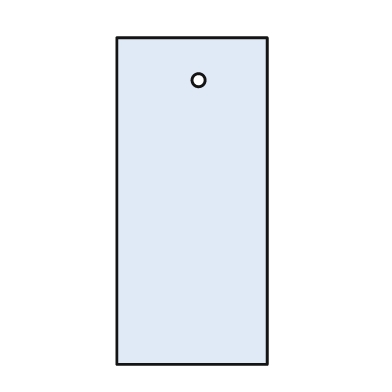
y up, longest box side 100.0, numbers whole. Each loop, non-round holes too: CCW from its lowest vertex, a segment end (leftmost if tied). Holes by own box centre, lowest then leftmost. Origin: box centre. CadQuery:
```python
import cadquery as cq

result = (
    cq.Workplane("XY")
    .moveTo(-23.0, -50.0)
    .lineTo(23.0, -50.0)
    .lineTo(23.0, 50.0)
    .lineTo(-23.0, 50.0)
    .close()
    .moveTo(2.0, 37.0)
    .circle(2.0)
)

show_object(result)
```